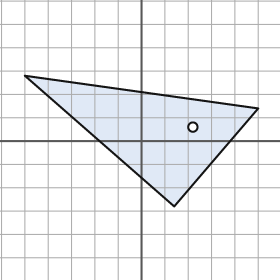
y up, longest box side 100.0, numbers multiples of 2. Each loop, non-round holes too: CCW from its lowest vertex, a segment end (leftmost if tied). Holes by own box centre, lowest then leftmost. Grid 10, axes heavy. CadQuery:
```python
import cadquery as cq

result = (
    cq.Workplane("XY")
    .moveTo(14.0, -28.0)
    .lineTo(50.0, 14.0)
    .lineTo(-50.0, 28.0)
    .close()
    .moveTo(22.0, 6.0)
    .circle(2.0)
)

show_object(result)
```